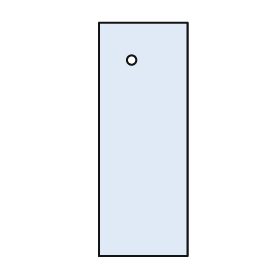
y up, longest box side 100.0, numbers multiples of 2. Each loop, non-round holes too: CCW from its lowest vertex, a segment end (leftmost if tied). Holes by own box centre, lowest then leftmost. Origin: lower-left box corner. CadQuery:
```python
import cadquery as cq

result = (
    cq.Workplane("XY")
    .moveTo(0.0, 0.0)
    .lineTo(38.0, 0.0)
    .lineTo(38.0, 100.0)
    .lineTo(0.0, 100.0)
    .close()
    .moveTo(14.0, 84.0)
    .circle(2.0)
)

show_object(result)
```